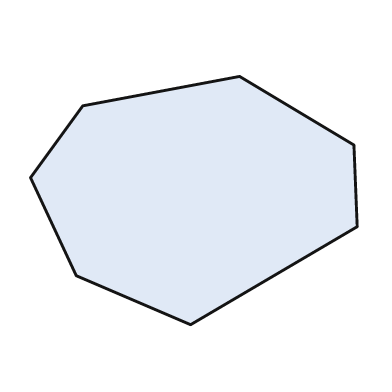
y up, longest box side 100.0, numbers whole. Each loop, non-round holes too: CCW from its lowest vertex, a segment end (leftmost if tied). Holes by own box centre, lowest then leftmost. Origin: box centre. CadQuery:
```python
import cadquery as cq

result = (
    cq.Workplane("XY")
    .moveTo(-1.0, -38.0)
    .lineTo(50.0, -8.0)
    .lineTo(49.0, 17.0)
    .lineTo(14.0, 38.0)
    .lineTo(-34.0, 29.0)
    .lineTo(-50.0, 7.0)
    .lineTo(-36.0, -23.0)
    .close()
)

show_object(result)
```